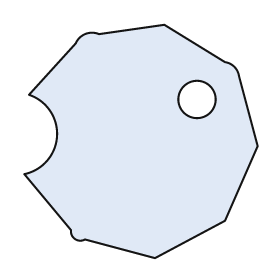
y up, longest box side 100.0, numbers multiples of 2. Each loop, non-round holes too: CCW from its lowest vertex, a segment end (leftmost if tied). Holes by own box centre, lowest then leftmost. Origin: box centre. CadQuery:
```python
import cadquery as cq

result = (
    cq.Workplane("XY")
    .moveTo(6.0, -50.0)
    .lineTo(36.0, -34.0)
    .lineTo(50.0, -2.0)
    .lineTo(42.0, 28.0)
    .threePointArc((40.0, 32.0), (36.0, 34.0))
    .lineTo(10.0, 50.0)
    .lineTo(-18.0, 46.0)
    .threePointArc((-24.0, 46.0), (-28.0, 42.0))
    .lineTo(-48.0, 20.0)
    .threePointArc((-36.0, 2.0), (-50.0, -14.0))
    .lineTo(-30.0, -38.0)
    .threePointArc((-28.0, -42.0), (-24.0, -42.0))
    .close()
    .moveTo(24.0, 18.0)
    .circle(8.0)
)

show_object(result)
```